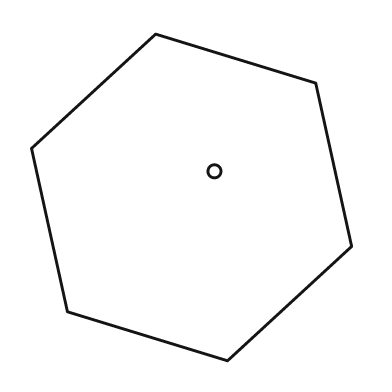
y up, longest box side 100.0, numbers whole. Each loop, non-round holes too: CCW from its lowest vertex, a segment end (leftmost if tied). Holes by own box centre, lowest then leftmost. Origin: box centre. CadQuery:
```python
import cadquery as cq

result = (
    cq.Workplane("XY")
    .moveTo(11.0, -50.0)
    .lineTo(49.0, -15.0)
    .lineTo(38.0, 35.0)
    .lineTo(-11.0, 50.0)
    .lineTo(-49.0, 15.0)
    .lineTo(-38.0, -35.0)
    .close()
    .moveTo(7.0, 8.0)
    .circle(2.0)
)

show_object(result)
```